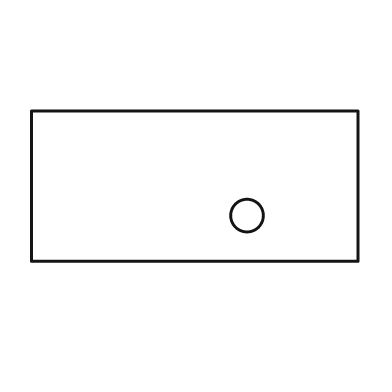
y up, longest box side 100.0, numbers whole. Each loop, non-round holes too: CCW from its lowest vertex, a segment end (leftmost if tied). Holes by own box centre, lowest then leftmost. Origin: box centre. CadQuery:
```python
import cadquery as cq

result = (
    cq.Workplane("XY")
    .moveTo(-50.0, -23.0)
    .lineTo(50.0, -23.0)
    .lineTo(50.0, 23.0)
    .lineTo(-50.0, 23.0)
    .close()
    .moveTo(16.0, -9.0)
    .circle(5.0)
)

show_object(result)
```